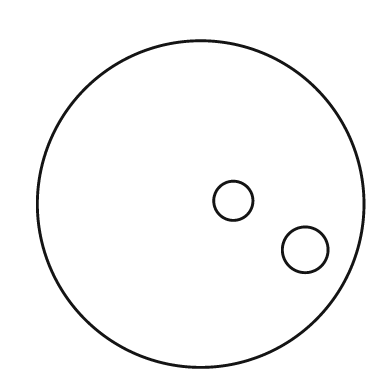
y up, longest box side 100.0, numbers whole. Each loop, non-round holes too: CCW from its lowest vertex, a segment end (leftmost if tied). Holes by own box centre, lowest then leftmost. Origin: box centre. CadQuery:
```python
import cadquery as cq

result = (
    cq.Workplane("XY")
    .moveTo(0.0, 0.0)
    .circle(50.0)
    .moveTo(32.0, -14.0)
    .circle(7.0)
    .moveTo(10.0, 1.0)
    .circle(6.0)
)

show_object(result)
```